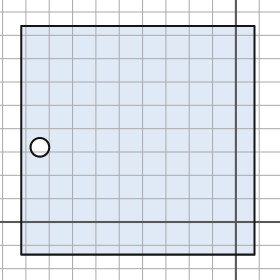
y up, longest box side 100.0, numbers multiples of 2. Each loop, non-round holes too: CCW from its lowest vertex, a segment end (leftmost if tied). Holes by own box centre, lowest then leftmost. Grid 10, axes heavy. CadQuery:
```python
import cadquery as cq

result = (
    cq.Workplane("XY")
    .moveTo(-92.0, -14.0)
    .lineTo(8.0, -14.0)
    .lineTo(8.0, 84.0)
    .lineTo(-92.0, 84.0)
    .close()
    .moveTo(-84.0, 32.0)
    .circle(4.0)
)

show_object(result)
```